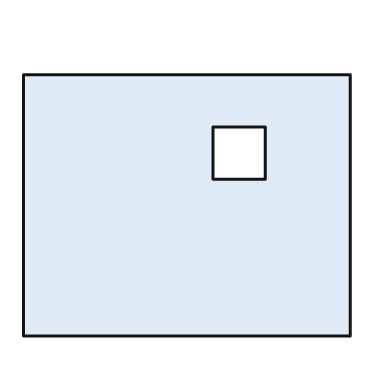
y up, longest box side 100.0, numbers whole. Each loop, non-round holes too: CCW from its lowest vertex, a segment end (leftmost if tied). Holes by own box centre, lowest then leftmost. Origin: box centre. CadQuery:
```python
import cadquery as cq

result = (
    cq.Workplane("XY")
    .moveTo(-50.0, -40.0)
    .lineTo(50.0, -40.0)
    .lineTo(50.0, 40.0)
    .lineTo(-50.0, 40.0)
    .close()
    .moveTo(8.0, 8.0)
    .lineTo(24.0, 8.0)
    .lineTo(24.0, 24.0)
    .lineTo(8.0, 24.0)
    .close()
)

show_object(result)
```